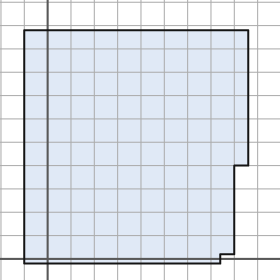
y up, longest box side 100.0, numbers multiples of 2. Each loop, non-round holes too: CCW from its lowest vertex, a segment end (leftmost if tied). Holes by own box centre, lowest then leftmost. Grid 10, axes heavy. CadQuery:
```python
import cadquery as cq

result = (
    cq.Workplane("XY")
    .moveTo(-10.0, -2.0)
    .lineTo(74.0, -2.0)
    .lineTo(74.0, 2.0)
    .lineTo(80.0, 2.0)
    .lineTo(80.0, 40.0)
    .lineTo(86.0, 40.0)
    .lineTo(86.0, 98.0)
    .lineTo(-10.0, 98.0)
    .close()
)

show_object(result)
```